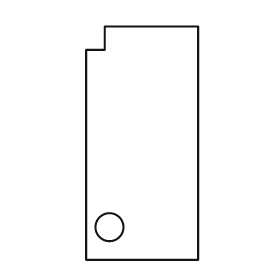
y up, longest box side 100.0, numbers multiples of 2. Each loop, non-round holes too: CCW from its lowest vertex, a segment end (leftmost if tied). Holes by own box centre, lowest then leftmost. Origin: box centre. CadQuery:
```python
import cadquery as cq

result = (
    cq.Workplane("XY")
    .moveTo(-24.0, -50.0)
    .lineTo(24.0, -50.0)
    .lineTo(24.0, 50.0)
    .lineTo(-16.0, 50.0)
    .lineTo(-16.0, 40.0)
    .lineTo(-24.0, 40.0)
    .close()
    .moveTo(-14.0, -36.0)
    .circle(6.0)
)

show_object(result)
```